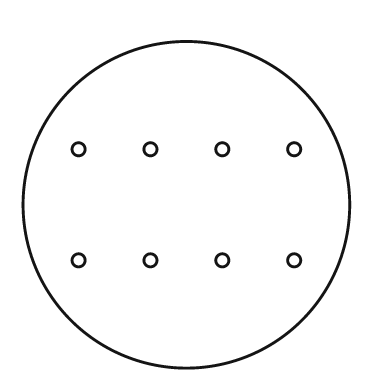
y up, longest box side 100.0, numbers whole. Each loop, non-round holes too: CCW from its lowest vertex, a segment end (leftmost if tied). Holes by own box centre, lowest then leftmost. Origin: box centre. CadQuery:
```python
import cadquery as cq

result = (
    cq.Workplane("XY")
    .moveTo(0.0, 0.0)
    .circle(50.0)
    .moveTo(-33.0, -17.0)
    .circle(2.0)
    .moveTo(-11.0, -17.0)
    .circle(2.0)
    .moveTo(11.0, -17.0)
    .circle(2.0)
    .moveTo(33.0, -17.0)
    .circle(2.0)
    .moveTo(-33.0, 17.0)
    .circle(2.0)
    .moveTo(-11.0, 17.0)
    .circle(2.0)
    .moveTo(11.0, 17.0)
    .circle(2.0)
    .moveTo(33.0, 17.0)
    .circle(2.0)
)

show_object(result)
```